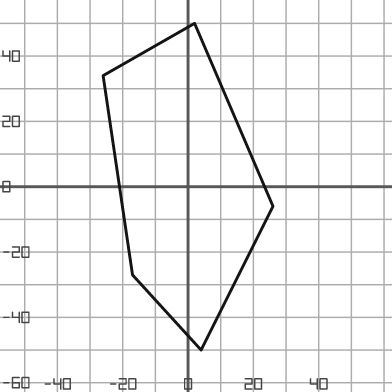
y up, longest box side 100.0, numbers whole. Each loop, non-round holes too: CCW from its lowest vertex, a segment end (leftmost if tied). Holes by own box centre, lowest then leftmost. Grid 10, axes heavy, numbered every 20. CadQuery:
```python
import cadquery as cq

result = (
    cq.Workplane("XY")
    .moveTo(4.0, -50.0)
    .lineTo(26.0, -6.0)
    .lineTo(2.0, 50.0)
    .lineTo(-26.0, 34.0)
    .lineTo(-17.0, -27.0)
    .close()
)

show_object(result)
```